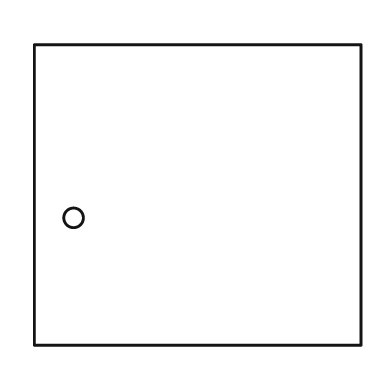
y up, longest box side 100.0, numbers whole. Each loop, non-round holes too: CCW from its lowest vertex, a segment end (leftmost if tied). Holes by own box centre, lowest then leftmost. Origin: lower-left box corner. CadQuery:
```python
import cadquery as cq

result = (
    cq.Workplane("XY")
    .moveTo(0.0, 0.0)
    .lineTo(100.0, 0.0)
    .lineTo(100.0, 92.0)
    .lineTo(0.0, 92.0)
    .close()
    .moveTo(12.0, 39.0)
    .circle(3.0)
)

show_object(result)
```